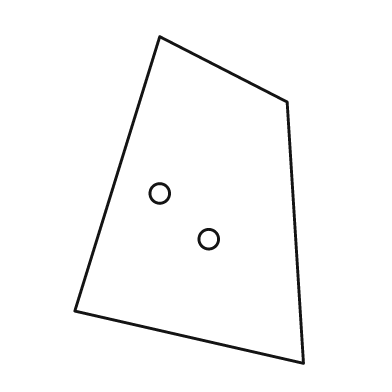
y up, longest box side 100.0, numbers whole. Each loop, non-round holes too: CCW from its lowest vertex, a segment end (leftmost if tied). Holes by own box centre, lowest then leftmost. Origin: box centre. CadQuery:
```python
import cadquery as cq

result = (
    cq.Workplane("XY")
    .moveTo(35.0, -50.0)
    .lineTo(30.0, 30.0)
    .lineTo(-9.0, 50.0)
    .lineTo(-35.0, -34.0)
    .close()
    .moveTo(6.0, -12.0)
    .circle(3.0)
    .moveTo(-9.0, 2.0)
    .circle(3.0)
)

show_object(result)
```